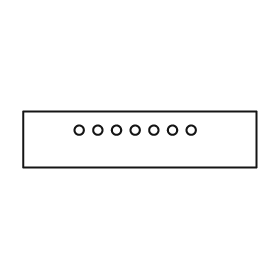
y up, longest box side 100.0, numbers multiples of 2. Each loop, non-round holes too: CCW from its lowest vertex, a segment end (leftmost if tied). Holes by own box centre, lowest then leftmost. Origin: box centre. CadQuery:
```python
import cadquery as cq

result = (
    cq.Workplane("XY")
    .moveTo(-50.0, -12.0)
    .lineTo(50.0, -12.0)
    .lineTo(50.0, 12.0)
    .lineTo(-50.0, 12.0)
    .close()
    .moveTo(-26.0, 4.0)
    .circle(2.0)
    .moveTo(-18.0, 4.0)
    .circle(2.0)
    .moveTo(-10.0, 4.0)
    .circle(2.0)
    .moveTo(-2.0, 4.0)
    .circle(2.0)
    .moveTo(6.0, 4.0)
    .circle(2.0)
    .moveTo(14.0, 4.0)
    .circle(2.0)
    .moveTo(22.0, 4.0)
    .circle(2.0)
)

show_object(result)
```